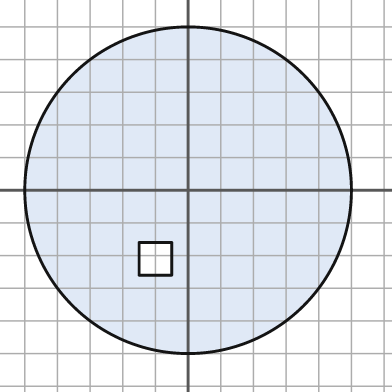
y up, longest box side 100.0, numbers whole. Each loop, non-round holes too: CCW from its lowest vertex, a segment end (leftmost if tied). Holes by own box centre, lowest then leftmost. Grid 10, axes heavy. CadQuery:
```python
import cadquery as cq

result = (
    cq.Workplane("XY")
    .moveTo(0.0, 0.0)
    .circle(50.0)
    .moveTo(-15.0, -26.0)
    .lineTo(-5.0, -26.0)
    .lineTo(-5.0, -16.0)
    .lineTo(-15.0, -16.0)
    .close()
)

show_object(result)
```